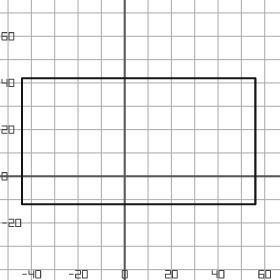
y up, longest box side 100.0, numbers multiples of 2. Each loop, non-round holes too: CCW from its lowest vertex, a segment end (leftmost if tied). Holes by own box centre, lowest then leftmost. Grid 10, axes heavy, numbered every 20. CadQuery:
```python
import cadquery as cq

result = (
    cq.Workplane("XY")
    .moveTo(-44.0, -12.0)
    .lineTo(56.0, -12.0)
    .lineTo(56.0, 42.0)
    .lineTo(-44.0, 42.0)
    .close()
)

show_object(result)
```